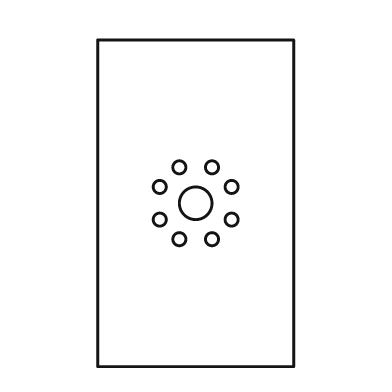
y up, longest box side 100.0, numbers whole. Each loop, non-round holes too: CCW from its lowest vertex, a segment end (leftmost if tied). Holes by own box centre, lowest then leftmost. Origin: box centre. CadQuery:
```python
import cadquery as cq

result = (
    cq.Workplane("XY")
    .moveTo(-30.0, -50.0)
    .lineTo(30.0, -50.0)
    .lineTo(30.0, 50.0)
    .lineTo(-30.0, 50.0)
    .close()
    .moveTo(-5.0, -11.0)
    .circle(2.0)
    .moveTo(5.0, -11.0)
    .circle(2.0)
    .moveTo(-11.0, -5.0)
    .circle(2.0)
    .moveTo(11.0, -5.0)
    .circle(2.0)
    .moveTo(0.0, 0.0)
    .circle(5.0)
    .moveTo(-11.0, 5.0)
    .circle(2.0)
    .moveTo(11.0, 5.0)
    .circle(2.0)
    .moveTo(-5.0, 11.0)
    .circle(2.0)
    .moveTo(5.0, 11.0)
    .circle(2.0)
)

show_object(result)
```